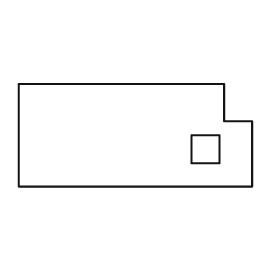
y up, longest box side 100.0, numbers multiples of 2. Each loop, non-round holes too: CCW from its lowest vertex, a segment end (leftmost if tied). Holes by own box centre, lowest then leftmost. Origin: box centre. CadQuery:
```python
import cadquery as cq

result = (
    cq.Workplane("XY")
    .moveTo(-50.0, -22.0)
    .lineTo(50.0, -22.0)
    .lineTo(50.0, 6.0)
    .lineTo(38.0, 6.0)
    .lineTo(38.0, 22.0)
    .lineTo(-50.0, 22.0)
    .close()
    .moveTo(24.0, -12.0)
    .lineTo(36.0, -12.0)
    .lineTo(36.0, 0.0)
    .lineTo(24.0, 0.0)
    .close()
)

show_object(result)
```